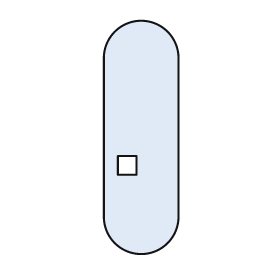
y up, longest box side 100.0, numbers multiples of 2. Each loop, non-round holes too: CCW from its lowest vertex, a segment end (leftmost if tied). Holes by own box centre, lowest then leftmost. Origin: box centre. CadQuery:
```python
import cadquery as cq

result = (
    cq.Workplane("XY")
    .moveTo(-16.0, -34.0)
    .threePointArc((0.0, -50.0), (16.0, -34.0))
    .lineTo(16.0, 34.0)
    .threePointArc((0.0, 50.0), (-16.0, 34.0))
    .close()
    .moveTo(-10.0, -16.0)
    .lineTo(-2.0, -16.0)
    .lineTo(-2.0, -8.0)
    .lineTo(-10.0, -8.0)
    .close()
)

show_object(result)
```